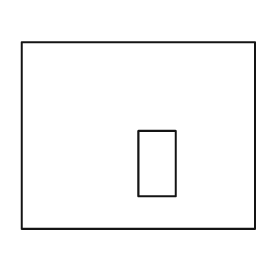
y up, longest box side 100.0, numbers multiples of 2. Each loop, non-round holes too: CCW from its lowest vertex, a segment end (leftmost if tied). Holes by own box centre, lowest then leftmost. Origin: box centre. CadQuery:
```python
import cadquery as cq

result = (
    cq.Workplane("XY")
    .moveTo(-50.0, -40.0)
    .lineTo(50.0, -40.0)
    .lineTo(50.0, 40.0)
    .lineTo(-50.0, 40.0)
    .close()
    .moveTo(0.0, -26.0)
    .lineTo(16.0, -26.0)
    .lineTo(16.0, 2.0)
    .lineTo(0.0, 2.0)
    .close()
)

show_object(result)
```